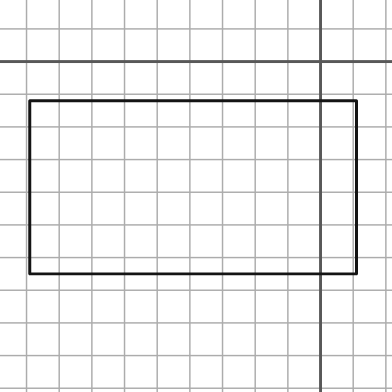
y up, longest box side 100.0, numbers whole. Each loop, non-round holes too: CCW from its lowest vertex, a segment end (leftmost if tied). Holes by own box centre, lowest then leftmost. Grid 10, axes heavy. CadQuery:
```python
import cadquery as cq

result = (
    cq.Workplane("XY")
    .moveTo(-89.0, -65.0)
    .lineTo(11.0, -65.0)
    .lineTo(11.0, -12.0)
    .lineTo(-89.0, -12.0)
    .close()
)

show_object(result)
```